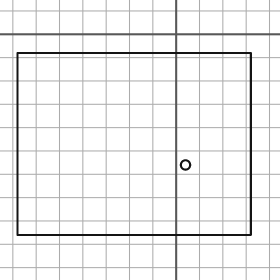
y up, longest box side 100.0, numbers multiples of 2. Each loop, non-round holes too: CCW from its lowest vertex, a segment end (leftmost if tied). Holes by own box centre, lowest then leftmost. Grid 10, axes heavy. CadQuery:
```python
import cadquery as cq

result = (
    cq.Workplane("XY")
    .moveTo(-68.0, -86.0)
    .lineTo(32.0, -86.0)
    .lineTo(32.0, -8.0)
    .lineTo(-68.0, -8.0)
    .close()
    .moveTo(4.0, -56.0)
    .circle(2.0)
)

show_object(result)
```